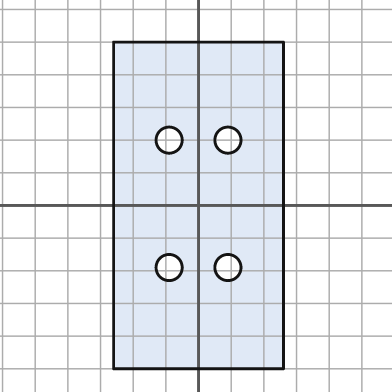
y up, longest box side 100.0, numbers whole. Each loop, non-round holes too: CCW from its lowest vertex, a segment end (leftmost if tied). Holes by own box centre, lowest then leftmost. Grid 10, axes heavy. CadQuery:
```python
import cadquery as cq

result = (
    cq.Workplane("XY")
    .moveTo(-26.0, -50.0)
    .lineTo(26.0, -50.0)
    .lineTo(26.0, 50.0)
    .lineTo(-26.0, 50.0)
    .close()
    .moveTo(-9.0, -19.0)
    .circle(4.0)
    .moveTo(9.0, -19.0)
    .circle(4.0)
    .moveTo(-9.0, 20.0)
    .circle(4.0)
    .moveTo(9.0, 20.0)
    .circle(4.0)
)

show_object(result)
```